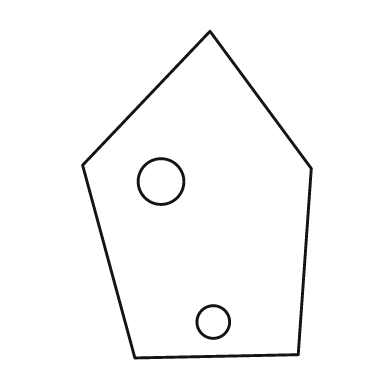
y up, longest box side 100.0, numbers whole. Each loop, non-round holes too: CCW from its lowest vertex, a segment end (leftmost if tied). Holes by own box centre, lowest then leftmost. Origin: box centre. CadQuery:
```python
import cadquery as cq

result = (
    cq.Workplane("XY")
    .moveTo(-19.0, -50.0)
    .lineTo(31.0, -49.0)
    .lineTo(35.0, 8.0)
    .lineTo(4.0, 50.0)
    .lineTo(-35.0, 9.0)
    .close()
    .moveTo(5.0, -39.0)
    .circle(5.0)
    .moveTo(-11.0, 4.0)
    .circle(7.0)
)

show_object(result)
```